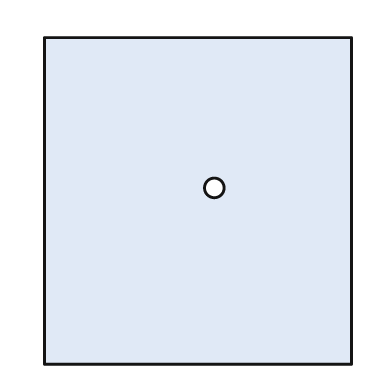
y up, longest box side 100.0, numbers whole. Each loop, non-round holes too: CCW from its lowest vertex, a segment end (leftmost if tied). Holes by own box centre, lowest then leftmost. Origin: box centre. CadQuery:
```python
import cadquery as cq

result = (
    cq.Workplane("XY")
    .moveTo(-47.0, -50.0)
    .lineTo(47.0, -50.0)
    .lineTo(47.0, 50.0)
    .lineTo(-47.0, 50.0)
    .close()
    .moveTo(5.0, 4.0)
    .circle(3.0)
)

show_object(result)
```